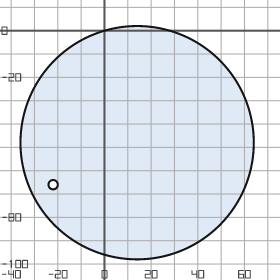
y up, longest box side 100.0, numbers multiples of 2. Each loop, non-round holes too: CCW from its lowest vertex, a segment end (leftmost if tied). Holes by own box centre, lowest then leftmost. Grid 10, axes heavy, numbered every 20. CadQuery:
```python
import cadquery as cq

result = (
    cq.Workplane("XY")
    .moveTo(14.0, -48.0)
    .circle(50.0)
    .moveTo(-22.0, -66.0)
    .circle(2.0)
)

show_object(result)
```